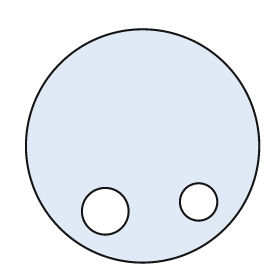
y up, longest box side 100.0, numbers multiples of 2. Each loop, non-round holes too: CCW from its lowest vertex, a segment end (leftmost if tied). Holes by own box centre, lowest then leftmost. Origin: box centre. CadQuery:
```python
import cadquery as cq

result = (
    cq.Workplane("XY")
    .moveTo(0.0, 0.0)
    .circle(50.0)
    .moveTo(-16.0, -28.0)
    .circle(10.0)
    .moveTo(24.0, -24.0)
    .circle(8.0)
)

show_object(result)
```